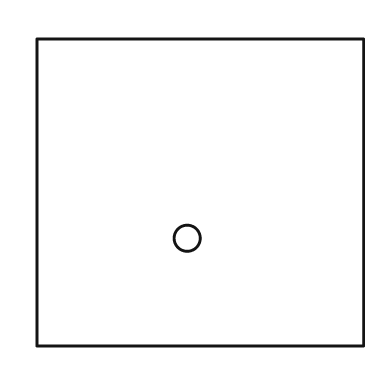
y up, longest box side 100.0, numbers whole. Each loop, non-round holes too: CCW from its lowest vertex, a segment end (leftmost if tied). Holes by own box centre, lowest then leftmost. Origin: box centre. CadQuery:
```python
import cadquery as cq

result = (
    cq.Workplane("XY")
    .moveTo(-50.0, -47.0)
    .lineTo(50.0, -47.0)
    .lineTo(50.0, 47.0)
    .lineTo(-50.0, 47.0)
    .close()
    .moveTo(-4.0, -14.0)
    .circle(4.0)
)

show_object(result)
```